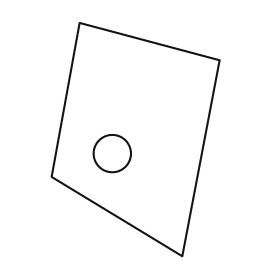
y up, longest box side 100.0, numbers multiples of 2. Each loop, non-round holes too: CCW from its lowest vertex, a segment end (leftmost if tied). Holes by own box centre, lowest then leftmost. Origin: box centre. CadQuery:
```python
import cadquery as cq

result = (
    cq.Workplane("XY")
    .moveTo(20.0, -50.0)
    .lineTo(36.0, 34.0)
    .lineTo(-24.0, 50.0)
    .lineTo(-36.0, -16.0)
    .close()
    .moveTo(-10.0, -6.0)
    .circle(8.0)
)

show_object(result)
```